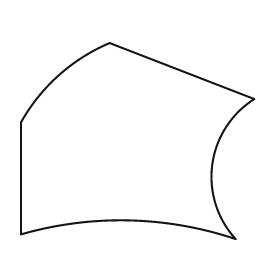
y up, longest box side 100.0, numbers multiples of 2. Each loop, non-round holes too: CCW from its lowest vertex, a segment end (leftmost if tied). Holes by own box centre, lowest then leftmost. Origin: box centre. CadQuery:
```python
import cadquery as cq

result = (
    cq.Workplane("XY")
    .moveTo(42.0, -42.0)
    .threePointArc((32.0, -10.0), (50.0, 18.0))
    .lineTo(-12.0, 42.0)
    .threePointArc((-34.0, 28.0), (-50.0, 8.0))
    .lineTo(-50.0, -40.0)
    .threePointArc((-4.0, -34.0), (42.0, -42.0))
    .close()
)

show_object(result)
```